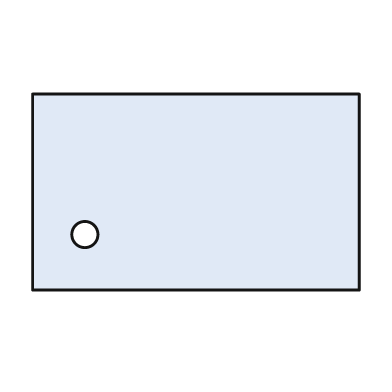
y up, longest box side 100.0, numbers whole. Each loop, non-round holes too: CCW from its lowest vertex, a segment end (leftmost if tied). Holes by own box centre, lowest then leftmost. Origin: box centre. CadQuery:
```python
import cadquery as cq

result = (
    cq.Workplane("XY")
    .moveTo(-50.0, -30.0)
    .lineTo(50.0, -30.0)
    .lineTo(50.0, 30.0)
    .lineTo(-50.0, 30.0)
    .close()
    .moveTo(-34.0, -13.0)
    .circle(4.0)
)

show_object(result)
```